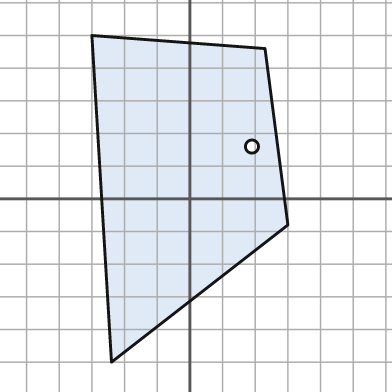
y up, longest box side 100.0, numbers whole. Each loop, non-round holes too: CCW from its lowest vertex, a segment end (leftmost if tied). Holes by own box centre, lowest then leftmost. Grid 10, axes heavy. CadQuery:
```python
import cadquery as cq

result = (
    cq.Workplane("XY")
    .moveTo(-24.0, -50.0)
    .lineTo(30.0, -8.0)
    .lineTo(23.0, 46.0)
    .lineTo(-30.0, 50.0)
    .close()
    .moveTo(19.0, 16.0)
    .circle(2.0)
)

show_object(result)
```